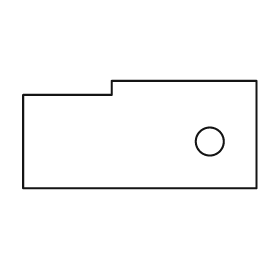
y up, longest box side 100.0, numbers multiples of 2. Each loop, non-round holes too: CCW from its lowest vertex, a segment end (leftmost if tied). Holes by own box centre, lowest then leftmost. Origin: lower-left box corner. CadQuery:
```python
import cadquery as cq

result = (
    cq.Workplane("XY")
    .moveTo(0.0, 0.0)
    .lineTo(100.0, 0.0)
    .lineTo(100.0, 46.0)
    .lineTo(38.0, 46.0)
    .lineTo(38.0, 40.0)
    .lineTo(0.0, 40.0)
    .close()
    .moveTo(80.0, 20.0)
    .circle(6.0)
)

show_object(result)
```